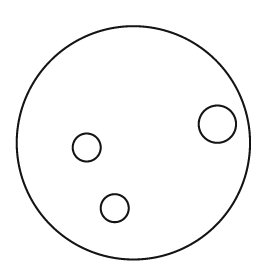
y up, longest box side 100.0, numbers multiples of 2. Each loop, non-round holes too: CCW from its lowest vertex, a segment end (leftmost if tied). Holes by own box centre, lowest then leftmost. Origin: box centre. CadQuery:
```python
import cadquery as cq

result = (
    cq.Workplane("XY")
    .moveTo(0.0, 0.0)
    .circle(50.0)
    .moveTo(-8.0, -28.0)
    .circle(6.0)
    .moveTo(-20.0, -2.0)
    .circle(6.0)
    .moveTo(36.0, 8.0)
    .circle(8.0)
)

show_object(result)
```